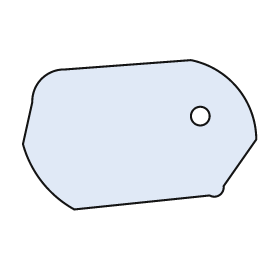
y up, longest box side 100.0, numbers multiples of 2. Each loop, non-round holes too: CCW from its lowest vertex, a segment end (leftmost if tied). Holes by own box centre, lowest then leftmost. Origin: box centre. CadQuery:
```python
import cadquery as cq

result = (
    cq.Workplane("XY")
    .moveTo(-28.0, -32.0)
    .lineTo(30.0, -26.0)
    .threePointArc((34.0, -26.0), (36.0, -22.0))
    .lineTo(50.0, -2.0)
    .threePointArc((42.0, 20.0), (22.0, 32.0))
    .lineTo(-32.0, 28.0)
    .threePointArc((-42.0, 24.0), (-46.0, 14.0))
    .lineTo(-50.0, -4.0)
    .threePointArc((-42.0, -20.0), (-28.0, -32.0))
    .close()
    .moveTo(26.0, 8.0)
    .circle(4.0)
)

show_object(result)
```